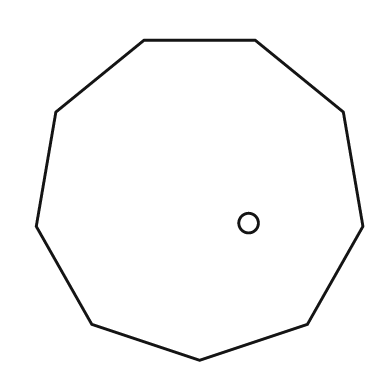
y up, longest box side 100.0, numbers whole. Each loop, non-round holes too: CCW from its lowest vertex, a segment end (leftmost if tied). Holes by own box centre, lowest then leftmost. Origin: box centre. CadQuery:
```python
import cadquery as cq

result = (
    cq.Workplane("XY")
    .moveTo(0.0, -49.0)
    .lineTo(33.0, -38.0)
    .lineTo(50.0, -8.0)
    .lineTo(44.0, 27.0)
    .lineTo(17.0, 49.0)
    .lineTo(-17.0, 49.0)
    .lineTo(-44.0, 27.0)
    .lineTo(-50.0, -8.0)
    .lineTo(-33.0, -38.0)
    .close()
    .moveTo(15.0, -7.0)
    .circle(3.0)
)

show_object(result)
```